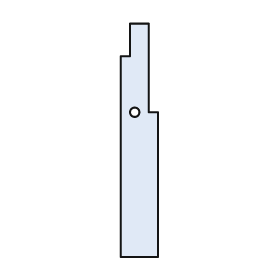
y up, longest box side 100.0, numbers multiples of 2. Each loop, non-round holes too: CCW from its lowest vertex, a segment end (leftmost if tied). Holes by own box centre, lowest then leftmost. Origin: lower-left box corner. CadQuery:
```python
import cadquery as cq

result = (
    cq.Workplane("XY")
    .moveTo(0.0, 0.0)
    .lineTo(16.0, 0.0)
    .lineTo(16.0, 62.0)
    .lineTo(12.0, 62.0)
    .lineTo(12.0, 100.0)
    .lineTo(4.0, 100.0)
    .lineTo(4.0, 86.0)
    .lineTo(0.0, 86.0)
    .close()
    .moveTo(6.0, 62.0)
    .circle(2.0)
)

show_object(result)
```